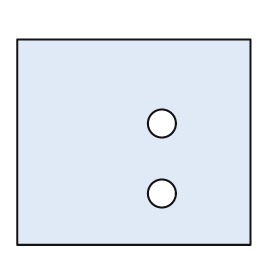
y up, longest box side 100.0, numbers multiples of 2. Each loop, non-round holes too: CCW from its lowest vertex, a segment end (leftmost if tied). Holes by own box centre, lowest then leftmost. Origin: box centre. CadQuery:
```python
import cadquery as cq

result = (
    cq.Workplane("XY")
    .moveTo(-50.0, -44.0)
    .lineTo(50.0, -44.0)
    .lineTo(50.0, 44.0)
    .lineTo(-50.0, 44.0)
    .close()
    .moveTo(12.0, -22.0)
    .circle(6.0)
    .moveTo(12.0, 8.0)
    .circle(6.0)
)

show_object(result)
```